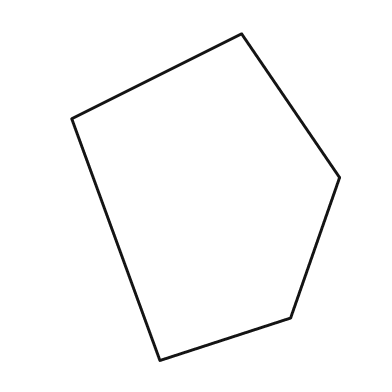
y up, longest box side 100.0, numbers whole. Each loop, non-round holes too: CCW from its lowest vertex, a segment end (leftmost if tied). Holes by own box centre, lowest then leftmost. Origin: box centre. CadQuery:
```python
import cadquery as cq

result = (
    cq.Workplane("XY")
    .moveTo(-14.0, -50.0)
    .lineTo(26.0, -37.0)
    .lineTo(41.0, 6.0)
    .lineTo(11.0, 50.0)
    .lineTo(-41.0, 24.0)
    .close()
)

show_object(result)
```